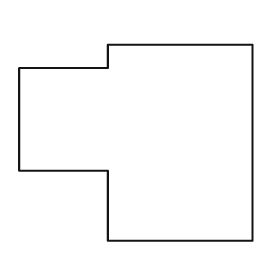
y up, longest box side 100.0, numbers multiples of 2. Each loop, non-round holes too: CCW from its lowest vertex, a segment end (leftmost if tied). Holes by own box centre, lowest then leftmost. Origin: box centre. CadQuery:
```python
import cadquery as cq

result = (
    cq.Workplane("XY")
    .moveTo(-12.0, -42.0)
    .lineTo(50.0, -42.0)
    .lineTo(50.0, 42.0)
    .lineTo(-12.0, 42.0)
    .lineTo(-12.0, 32.0)
    .lineTo(-50.0, 32.0)
    .lineTo(-50.0, -12.0)
    .lineTo(-12.0, -12.0)
    .close()
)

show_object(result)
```